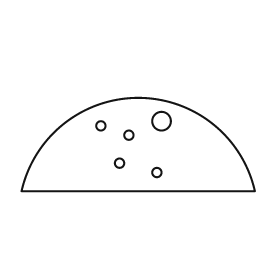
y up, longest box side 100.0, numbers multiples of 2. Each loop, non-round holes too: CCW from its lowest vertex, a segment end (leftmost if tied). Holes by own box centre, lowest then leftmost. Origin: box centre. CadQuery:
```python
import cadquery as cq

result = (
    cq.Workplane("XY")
    .moveTo(-50.0, -20.0)
    .lineTo(50.0, -20.0)
    .threePointArc((0.0, 20.0), (-50.0, -20.0))
    .close()
    .moveTo(8.0, -12.0)
    .circle(2.0)
    .moveTo(-8.0, -8.0)
    .circle(2.0)
    .moveTo(-4.0, 4.0)
    .circle(2.0)
    .moveTo(-16.0, 8.0)
    .circle(2.0)
    .moveTo(10.0, 10.0)
    .circle(4.0)
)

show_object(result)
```